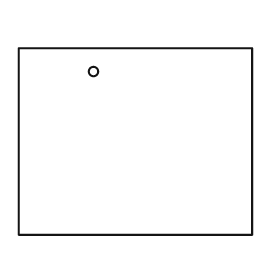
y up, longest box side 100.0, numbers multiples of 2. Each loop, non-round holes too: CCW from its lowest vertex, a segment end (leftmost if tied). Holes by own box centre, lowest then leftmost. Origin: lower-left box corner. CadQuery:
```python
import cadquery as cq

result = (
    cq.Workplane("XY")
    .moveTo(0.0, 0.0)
    .lineTo(100.0, 0.0)
    .lineTo(100.0, 80.0)
    .lineTo(0.0, 80.0)
    .close()
    .moveTo(32.0, 70.0)
    .circle(2.0)
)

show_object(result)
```